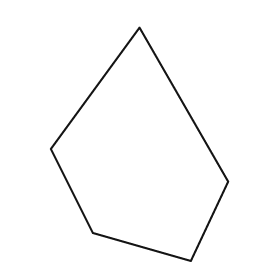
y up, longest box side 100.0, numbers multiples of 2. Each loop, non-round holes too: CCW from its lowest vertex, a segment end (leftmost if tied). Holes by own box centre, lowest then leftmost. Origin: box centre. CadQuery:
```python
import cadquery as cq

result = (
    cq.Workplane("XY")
    .moveTo(22.0, -50.0)
    .lineTo(38.0, -16.0)
    .lineTo(0.0, 50.0)
    .lineTo(-38.0, -2.0)
    .lineTo(-20.0, -38.0)
    .close()
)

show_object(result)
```